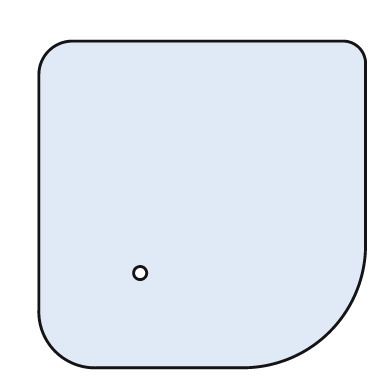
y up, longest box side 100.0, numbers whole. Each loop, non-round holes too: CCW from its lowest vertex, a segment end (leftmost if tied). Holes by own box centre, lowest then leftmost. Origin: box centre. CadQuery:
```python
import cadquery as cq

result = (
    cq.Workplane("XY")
    .moveTo(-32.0, -50.0)
    .lineTo(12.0, -50.0)
    .threePointArc((39.0, -39.0), (50.0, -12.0))
    .lineTo(50.0, 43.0)
    .threePointArc((48.0, 48.0), (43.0, 50.0))
    .lineTo(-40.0, 50.0)
    .threePointArc((-47.0, 47.0), (-50.0, 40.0))
    .lineTo(-50.0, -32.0)
    .threePointArc((-45.0, -45.0), (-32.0, -50.0))
    .close()
    .moveTo(-19.0, -21.0)
    .circle(2.0)
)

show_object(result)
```